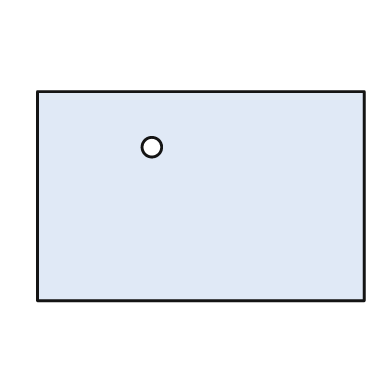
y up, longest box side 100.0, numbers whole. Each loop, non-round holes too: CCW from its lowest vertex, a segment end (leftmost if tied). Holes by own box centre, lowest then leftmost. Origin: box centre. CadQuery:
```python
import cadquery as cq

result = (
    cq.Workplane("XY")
    .moveTo(-50.0, -32.0)
    .lineTo(50.0, -32.0)
    .lineTo(50.0, 32.0)
    .lineTo(-50.0, 32.0)
    .close()
    .moveTo(-15.0, 15.0)
    .circle(3.0)
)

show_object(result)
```